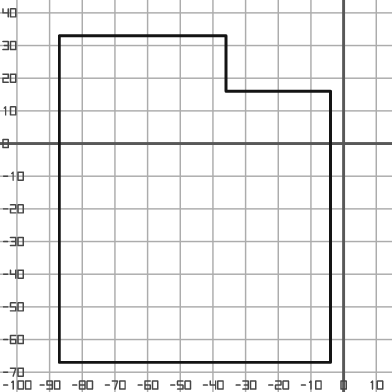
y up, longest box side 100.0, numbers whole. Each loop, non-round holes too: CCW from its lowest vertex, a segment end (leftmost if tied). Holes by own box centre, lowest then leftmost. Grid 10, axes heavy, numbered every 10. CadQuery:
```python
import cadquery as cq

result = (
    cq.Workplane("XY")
    .moveTo(-87.0, -67.0)
    .lineTo(-4.0, -67.0)
    .lineTo(-4.0, 16.0)
    .lineTo(-36.0, 16.0)
    .lineTo(-36.0, 33.0)
    .lineTo(-87.0, 33.0)
    .close()
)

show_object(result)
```